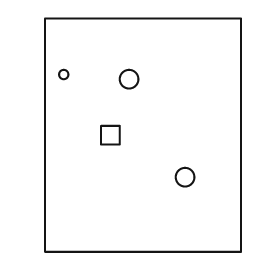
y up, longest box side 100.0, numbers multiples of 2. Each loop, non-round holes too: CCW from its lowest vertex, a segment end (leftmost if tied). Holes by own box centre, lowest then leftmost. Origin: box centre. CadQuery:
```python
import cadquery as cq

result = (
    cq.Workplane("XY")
    .moveTo(-42.0, -50.0)
    .lineTo(42.0, -50.0)
    .lineTo(42.0, 50.0)
    .lineTo(-42.0, 50.0)
    .close()
    .moveTo(18.0, -18.0)
    .circle(4.0)
    .moveTo(-18.0, -4.0)
    .lineTo(-10.0, -4.0)
    .lineTo(-10.0, 4.0)
    .lineTo(-18.0, 4.0)
    .close()
    .moveTo(-6.0, 24.0)
    .circle(4.0)
    .moveTo(-34.0, 26.0)
    .circle(2.0)
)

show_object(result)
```